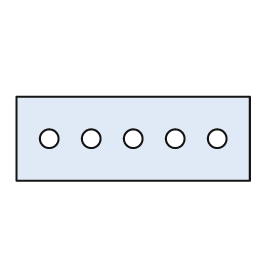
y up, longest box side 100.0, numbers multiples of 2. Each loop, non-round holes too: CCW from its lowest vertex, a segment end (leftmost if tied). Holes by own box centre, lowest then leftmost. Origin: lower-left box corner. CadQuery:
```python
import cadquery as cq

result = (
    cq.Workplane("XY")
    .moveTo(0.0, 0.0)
    .lineTo(100.0, 0.0)
    .lineTo(100.0, 36.0)
    .lineTo(0.0, 36.0)
    .close()
    .moveTo(14.0, 18.0)
    .circle(4.0)
    .moveTo(32.0, 18.0)
    .circle(4.0)
    .moveTo(50.0, 18.0)
    .circle(4.0)
    .moveTo(68.0, 18.0)
    .circle(4.0)
    .moveTo(86.0, 18.0)
    .circle(4.0)
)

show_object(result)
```